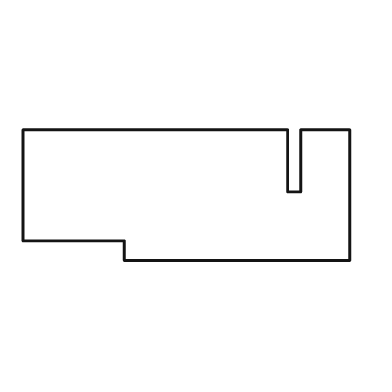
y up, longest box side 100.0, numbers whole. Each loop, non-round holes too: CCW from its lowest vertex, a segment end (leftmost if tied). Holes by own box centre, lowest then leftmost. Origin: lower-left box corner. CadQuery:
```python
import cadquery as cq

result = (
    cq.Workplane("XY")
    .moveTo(31.0, 0.0)
    .lineTo(100.0, 0.0)
    .lineTo(100.0, 40.0)
    .lineTo(85.0, 40.0)
    .lineTo(85.0, 21.0)
    .lineTo(81.0, 21.0)
    .lineTo(81.0, 40.0)
    .lineTo(0.0, 40.0)
    .lineTo(0.0, 6.0)
    .lineTo(31.0, 6.0)
    .close()
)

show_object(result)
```